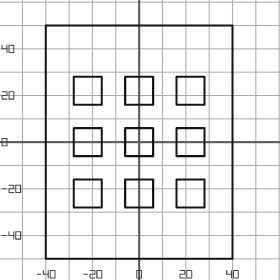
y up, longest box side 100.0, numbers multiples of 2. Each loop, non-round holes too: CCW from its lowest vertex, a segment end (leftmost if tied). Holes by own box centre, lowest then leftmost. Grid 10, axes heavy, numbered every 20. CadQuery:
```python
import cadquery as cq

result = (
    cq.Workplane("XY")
    .moveTo(-40.0, -50.0)
    .lineTo(40.0, -50.0)
    .lineTo(40.0, 50.0)
    .lineTo(-40.0, 50.0)
    .close()
    .moveTo(-28.0, -28.0)
    .lineTo(-16.0, -28.0)
    .lineTo(-16.0, -16.0)
    .lineTo(-28.0, -16.0)
    .close()
    .moveTo(-6.0, -28.0)
    .lineTo(6.0, -28.0)
    .lineTo(6.0, -16.0)
    .lineTo(-6.0, -16.0)
    .close()
    .moveTo(16.0, -28.0)
    .lineTo(28.0, -28.0)
    .lineTo(28.0, -16.0)
    .lineTo(16.0, -16.0)
    .close()
    .moveTo(-28.0, -6.0)
    .lineTo(-16.0, -6.0)
    .lineTo(-16.0, 6.0)
    .lineTo(-28.0, 6.0)
    .close()
    .moveTo(-6.0, -6.0)
    .lineTo(6.0, -6.0)
    .lineTo(6.0, 6.0)
    .lineTo(-6.0, 6.0)
    .close()
    .moveTo(16.0, -6.0)
    .lineTo(28.0, -6.0)
    .lineTo(28.0, 6.0)
    .lineTo(16.0, 6.0)
    .close()
    .moveTo(-28.0, 16.0)
    .lineTo(-16.0, 16.0)
    .lineTo(-16.0, 28.0)
    .lineTo(-28.0, 28.0)
    .close()
    .moveTo(-6.0, 16.0)
    .lineTo(6.0, 16.0)
    .lineTo(6.0, 28.0)
    .lineTo(-6.0, 28.0)
    .close()
    .moveTo(16.0, 16.0)
    .lineTo(28.0, 16.0)
    .lineTo(28.0, 28.0)
    .lineTo(16.0, 28.0)
    .close()
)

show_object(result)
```